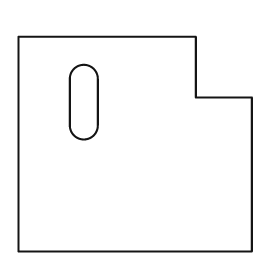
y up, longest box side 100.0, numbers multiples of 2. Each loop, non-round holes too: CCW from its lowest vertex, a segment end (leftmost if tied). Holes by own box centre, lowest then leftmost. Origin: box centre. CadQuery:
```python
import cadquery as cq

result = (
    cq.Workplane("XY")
    .moveTo(-50.0, -46.0)
    .lineTo(50.0, -46.0)
    .lineTo(50.0, 20.0)
    .lineTo(26.0, 20.0)
    .lineTo(26.0, 46.0)
    .lineTo(-50.0, 46.0)
    .close()
    .moveTo(-28.0, 8.0)
    .threePointArc((-22.0, 2.0), (-16.0, 8.0))
    .lineTo(-16.0, 28.0)
    .threePointArc((-22.0, 34.0), (-28.0, 28.0))
    .close()
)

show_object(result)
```